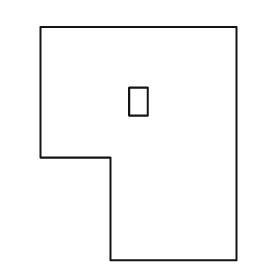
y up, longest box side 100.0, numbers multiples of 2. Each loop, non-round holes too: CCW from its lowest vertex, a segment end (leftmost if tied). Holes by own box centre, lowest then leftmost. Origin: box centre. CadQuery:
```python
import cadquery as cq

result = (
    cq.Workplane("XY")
    .moveTo(-12.0, -50.0)
    .lineTo(42.0, -50.0)
    .lineTo(42.0, 50.0)
    .lineTo(-42.0, 50.0)
    .lineTo(-42.0, -6.0)
    .lineTo(-12.0, -6.0)
    .close()
    .moveTo(-4.0, 12.0)
    .lineTo(4.0, 12.0)
    .lineTo(4.0, 24.0)
    .lineTo(-4.0, 24.0)
    .close()
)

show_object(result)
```